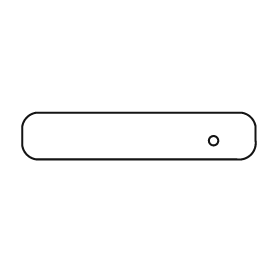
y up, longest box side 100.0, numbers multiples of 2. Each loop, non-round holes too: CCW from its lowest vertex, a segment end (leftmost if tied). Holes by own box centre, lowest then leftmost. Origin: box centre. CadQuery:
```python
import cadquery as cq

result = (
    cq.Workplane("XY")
    .moveTo(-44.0, -10.0)
    .lineTo(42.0, -10.0)
    .threePointArc((48.0, -8.0), (50.0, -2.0))
    .lineTo(50.0, 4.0)
    .threePointArc((48.0, 8.0), (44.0, 10.0))
    .lineTo(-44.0, 10.0)
    .threePointArc((-48.0, 8.0), (-50.0, 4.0))
    .lineTo(-50.0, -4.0)
    .threePointArc((-48.0, -8.0), (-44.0, -10.0))
    .close()
    .moveTo(32.0, -2.0)
    .circle(2.0)
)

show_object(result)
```